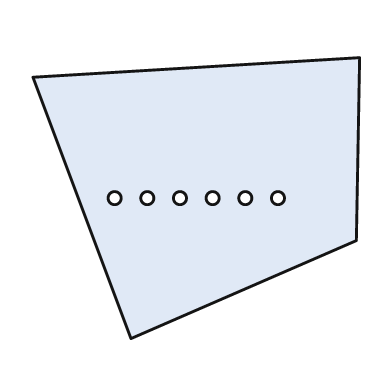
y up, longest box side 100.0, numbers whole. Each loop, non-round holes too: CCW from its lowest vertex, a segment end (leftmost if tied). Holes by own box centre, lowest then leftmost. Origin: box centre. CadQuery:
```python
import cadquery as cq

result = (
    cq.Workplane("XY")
    .moveTo(-20.0, -43.0)
    .lineTo(49.0, -13.0)
    .lineTo(50.0, 43.0)
    .lineTo(-50.0, 37.0)
    .close()
    .moveTo(-25.0, 0.0)
    .circle(2.0)
    .moveTo(-15.0, 0.0)
    .circle(2.0)
    .moveTo(-5.0, 0.0)
    .circle(2.0)
    .moveTo(5.0, 0.0)
    .circle(2.0)
    .moveTo(15.0, 0.0)
    .circle(2.0)
    .moveTo(25.0, 0.0)
    .circle(2.0)
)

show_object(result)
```